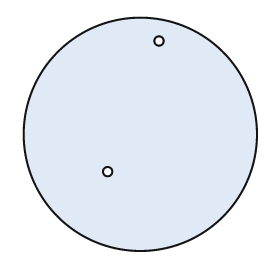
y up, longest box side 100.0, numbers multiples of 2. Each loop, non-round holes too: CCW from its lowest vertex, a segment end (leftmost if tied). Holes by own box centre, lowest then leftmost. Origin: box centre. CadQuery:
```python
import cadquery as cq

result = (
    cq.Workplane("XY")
    .moveTo(0.0, 0.0)
    .circle(50.0)
    .moveTo(-14.0, -16.0)
    .circle(2.0)
    .moveTo(8.0, 40.0)
    .circle(2.0)
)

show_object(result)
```